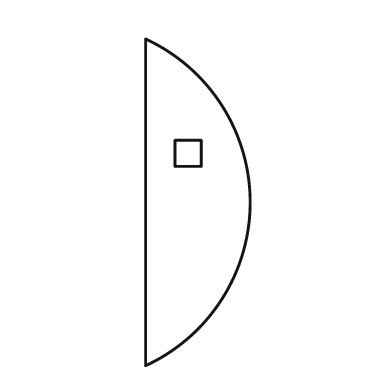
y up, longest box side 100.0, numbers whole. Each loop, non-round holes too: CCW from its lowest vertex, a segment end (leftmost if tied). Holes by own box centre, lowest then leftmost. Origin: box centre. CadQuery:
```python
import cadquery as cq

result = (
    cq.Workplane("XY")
    .moveTo(-16.0, -50.0)
    .threePointArc((16.0, 0.0), (-16.0, 50.0))
    .close()
    .moveTo(-7.0, 11.0)
    .lineTo(1.0, 11.0)
    .lineTo(1.0, 19.0)
    .lineTo(-7.0, 19.0)
    .close()
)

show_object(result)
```